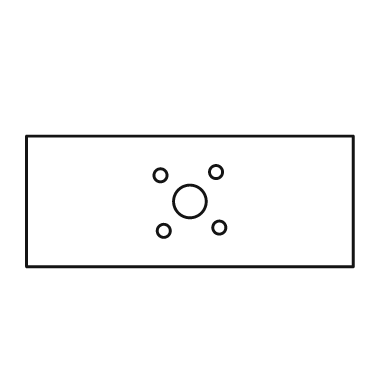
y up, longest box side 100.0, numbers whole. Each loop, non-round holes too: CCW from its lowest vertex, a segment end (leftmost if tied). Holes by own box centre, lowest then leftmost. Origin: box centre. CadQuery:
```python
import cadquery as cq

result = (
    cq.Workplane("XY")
    .moveTo(-50.0, -20.0)
    .lineTo(50.0, -20.0)
    .lineTo(50.0, 20.0)
    .lineTo(-50.0, 20.0)
    .close()
    .moveTo(-8.0, -9.0)
    .circle(2.0)
    .moveTo(9.0, -8.0)
    .circle(2.0)
    .moveTo(0.0, 0.0)
    .circle(5.0)
    .moveTo(-9.0, 8.0)
    .circle(2.0)
    .moveTo(8.0, 9.0)
    .circle(2.0)
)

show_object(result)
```